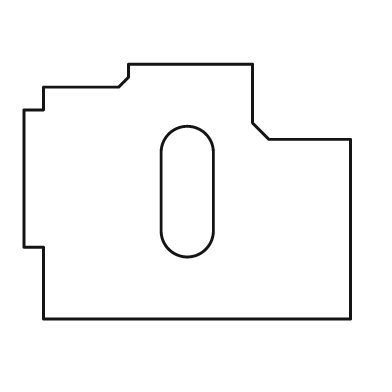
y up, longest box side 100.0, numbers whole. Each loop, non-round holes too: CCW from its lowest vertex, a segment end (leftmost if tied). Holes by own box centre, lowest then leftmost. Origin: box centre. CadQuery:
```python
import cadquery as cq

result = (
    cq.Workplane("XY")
    .moveTo(-44.0, -39.0)
    .lineTo(50.0, -39.0)
    .lineTo(50.0, 16.0)
    .lineTo(25.0, 16.0)
    .lineTo(20.0, 21.0)
    .lineTo(20.0, 39.0)
    .lineTo(-18.0, 39.0)
    .lineTo(-18.0, 35.0)
    .lineTo(-21.0, 32.0)
    .lineTo(-44.0, 32.0)
    .lineTo(-44.0, 25.0)
    .lineTo(-50.0, 25.0)
    .lineTo(-50.0, -17.0)
    .lineTo(-44.0, -17.0)
    .close()
    .moveTo(-8.0, -12.0)
    .threePointArc((0.0, -20.0), (8.0, -12.0))
    .lineTo(8.0, 12.0)
    .threePointArc((0.0, 20.0), (-8.0, 12.0))
    .close()
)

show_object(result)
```